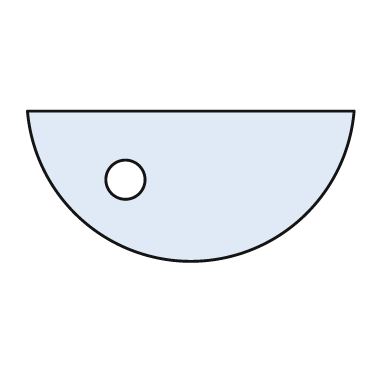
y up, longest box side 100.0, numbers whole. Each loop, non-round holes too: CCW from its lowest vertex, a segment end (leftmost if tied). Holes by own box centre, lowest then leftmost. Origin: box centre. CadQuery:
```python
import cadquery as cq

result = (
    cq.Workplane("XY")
    .moveTo(-50.0, 23.0)
    .threePointArc((0.0, -23.0), (50.0, 23.0))
    .close()
    .moveTo(-20.0, 2.0)
    .circle(6.0)
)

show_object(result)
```